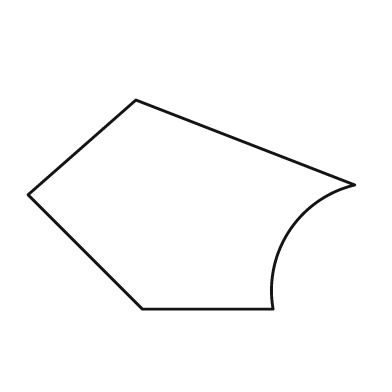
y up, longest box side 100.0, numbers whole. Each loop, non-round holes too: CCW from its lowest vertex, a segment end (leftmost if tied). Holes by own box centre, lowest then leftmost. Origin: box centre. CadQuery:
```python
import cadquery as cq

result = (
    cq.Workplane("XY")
    .moveTo(-15.0, -32.0)
    .lineTo(25.0, -32.0)
    .threePointArc((30.0, -8.0), (50.0, 6.0))
    .lineTo(-17.0, 32.0)
    .lineTo(-50.0, 3.0)
    .close()
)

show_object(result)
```